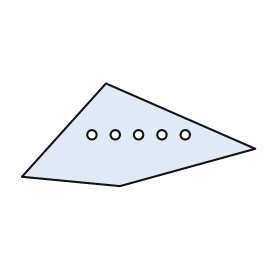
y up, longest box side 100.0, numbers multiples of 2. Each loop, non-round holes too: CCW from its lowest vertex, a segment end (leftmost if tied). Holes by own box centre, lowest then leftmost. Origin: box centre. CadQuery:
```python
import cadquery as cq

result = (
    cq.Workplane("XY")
    .moveTo(-8.0, -22.0)
    .lineTo(50.0, -6.0)
    .lineTo(-14.0, 22.0)
    .lineTo(-50.0, -18.0)
    .close()
    .moveTo(-20.0, 0.0)
    .circle(2.0)
    .moveTo(-10.0, 0.0)
    .circle(2.0)
    .moveTo(0.0, 0.0)
    .circle(2.0)
    .moveTo(10.0, 0.0)
    .circle(2.0)
    .moveTo(20.0, 0.0)
    .circle(2.0)
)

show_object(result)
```